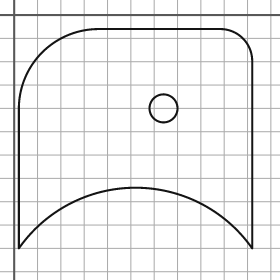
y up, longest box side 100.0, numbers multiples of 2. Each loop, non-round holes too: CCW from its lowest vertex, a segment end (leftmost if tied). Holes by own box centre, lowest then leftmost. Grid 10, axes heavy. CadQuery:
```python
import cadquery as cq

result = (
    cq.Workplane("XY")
    .moveTo(2.0, -100.0)
    .threePointArc((52.0, -74.0), (102.0, -100.0))
    .lineTo(102.0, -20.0)
    .threePointArc((98.0, -10.0), (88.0, -6.0))
    .lineTo(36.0, -6.0)
    .threePointArc((12.0, -16.0), (2.0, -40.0))
    .close()
    .moveTo(64.0, -40.0)
    .circle(6.0)
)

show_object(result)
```